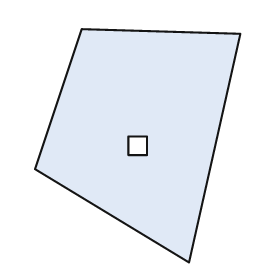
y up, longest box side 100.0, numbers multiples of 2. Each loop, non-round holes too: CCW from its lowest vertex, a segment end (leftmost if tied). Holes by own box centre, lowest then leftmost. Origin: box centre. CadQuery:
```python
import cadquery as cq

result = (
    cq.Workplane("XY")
    .moveTo(22.0, -50.0)
    .lineTo(44.0, 48.0)
    .lineTo(-24.0, 50.0)
    .lineTo(-44.0, -10.0)
    .close()
    .moveTo(-4.0, -4.0)
    .lineTo(4.0, -4.0)
    .lineTo(4.0, 4.0)
    .lineTo(-4.0, 4.0)
    .close()
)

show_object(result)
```